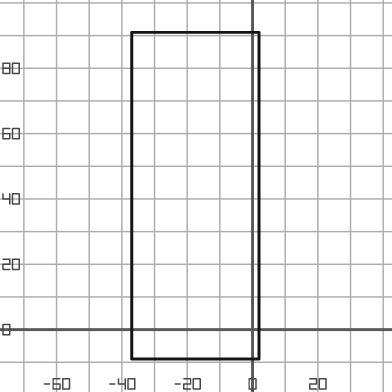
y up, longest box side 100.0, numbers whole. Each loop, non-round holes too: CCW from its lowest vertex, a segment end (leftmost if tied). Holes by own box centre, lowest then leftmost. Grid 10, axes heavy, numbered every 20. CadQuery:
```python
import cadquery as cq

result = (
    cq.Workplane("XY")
    .moveTo(-37.0, -9.0)
    .lineTo(2.0, -9.0)
    .lineTo(2.0, 91.0)
    .lineTo(-37.0, 91.0)
    .close()
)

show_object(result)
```